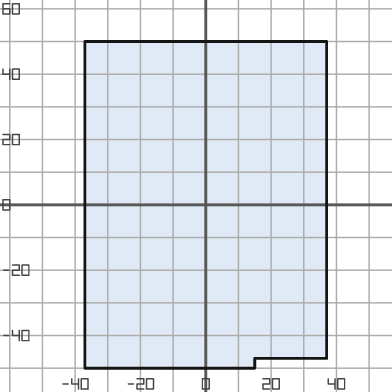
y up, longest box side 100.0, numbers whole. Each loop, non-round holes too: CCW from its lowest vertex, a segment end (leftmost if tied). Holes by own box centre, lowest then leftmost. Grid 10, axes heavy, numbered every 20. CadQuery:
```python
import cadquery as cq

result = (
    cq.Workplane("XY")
    .moveTo(-37.0, -50.0)
    .lineTo(15.0, -50.0)
    .lineTo(15.0, -47.0)
    .lineTo(37.0, -47.0)
    .lineTo(37.0, 50.0)
    .lineTo(-37.0, 50.0)
    .close()
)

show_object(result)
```